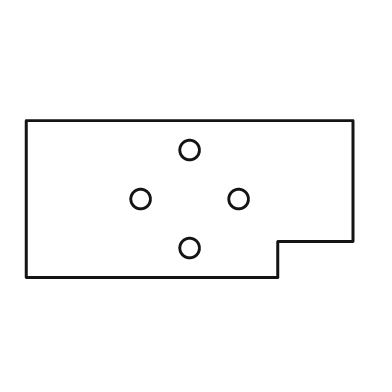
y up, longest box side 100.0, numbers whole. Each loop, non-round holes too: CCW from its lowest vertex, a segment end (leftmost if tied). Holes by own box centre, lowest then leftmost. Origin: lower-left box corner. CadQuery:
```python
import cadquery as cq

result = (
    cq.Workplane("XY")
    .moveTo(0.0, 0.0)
    .lineTo(77.0, 0.0)
    .lineTo(77.0, 11.0)
    .lineTo(100.0, 11.0)
    .lineTo(100.0, 48.0)
    .lineTo(0.0, 48.0)
    .close()
    .moveTo(50.0, 9.0)
    .circle(3.0)
    .moveTo(35.0, 24.0)
    .circle(3.0)
    .moveTo(65.0, 24.0)
    .circle(3.0)
    .moveTo(50.0, 39.0)
    .circle(3.0)
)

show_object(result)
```